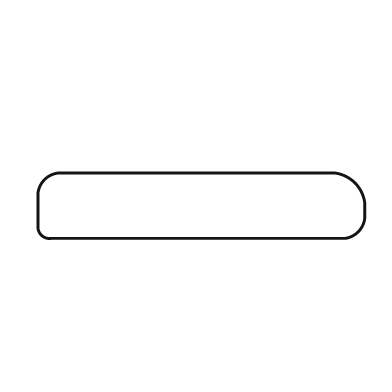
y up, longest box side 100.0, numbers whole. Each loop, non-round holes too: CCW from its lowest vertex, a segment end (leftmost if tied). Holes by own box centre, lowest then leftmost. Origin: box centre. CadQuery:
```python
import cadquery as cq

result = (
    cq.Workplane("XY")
    .moveTo(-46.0, -10.0)
    .lineTo(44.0, -10.0)
    .threePointArc((48.0, -8.0), (50.0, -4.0))
    .lineTo(50.0, 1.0)
    .threePointArc((47.0, 7.0), (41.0, 10.0))
    .lineTo(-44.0, 10.0)
    .threePointArc((-48.0, 8.0), (-50.0, 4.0))
    .lineTo(-50.0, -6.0)
    .threePointArc((-49.0, -9.0), (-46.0, -10.0))
    .close()
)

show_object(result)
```